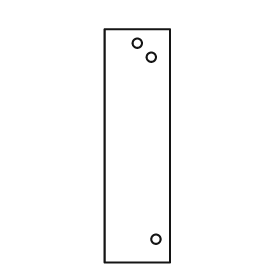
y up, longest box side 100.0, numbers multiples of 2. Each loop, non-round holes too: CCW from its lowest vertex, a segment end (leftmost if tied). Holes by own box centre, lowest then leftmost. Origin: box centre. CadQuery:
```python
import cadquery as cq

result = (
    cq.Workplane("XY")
    .moveTo(-14.0, -50.0)
    .lineTo(14.0, -50.0)
    .lineTo(14.0, 50.0)
    .lineTo(-14.0, 50.0)
    .close()
    .moveTo(8.0, -40.0)
    .circle(2.0)
    .moveTo(6.0, 38.0)
    .circle(2.0)
    .moveTo(0.0, 44.0)
    .circle(2.0)
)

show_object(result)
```